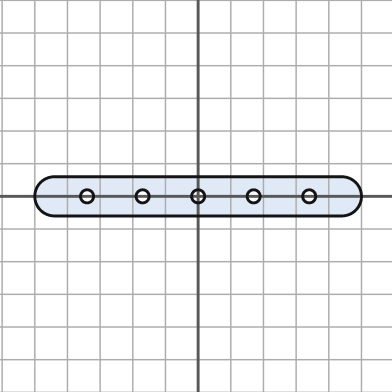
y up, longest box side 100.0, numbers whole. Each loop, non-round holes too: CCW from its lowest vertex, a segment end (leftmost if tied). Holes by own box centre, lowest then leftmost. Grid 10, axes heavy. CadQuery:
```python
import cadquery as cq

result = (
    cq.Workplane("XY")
    .moveTo(-44.0, -6.0)
    .lineTo(44.0, -6.0)
    .threePointArc((50.0, 0.0), (44.0, 6.0))
    .lineTo(-44.0, 6.0)
    .threePointArc((-50.0, 0.0), (-44.0, -6.0))
    .close()
    .moveTo(-34.0, 0.0)
    .circle(2.0)
    .moveTo(-17.0, 0.0)
    .circle(2.0)
    .moveTo(0.0, 0.0)
    .circle(2.0)
    .moveTo(17.0, 0.0)
    .circle(2.0)
    .moveTo(34.0, 0.0)
    .circle(2.0)
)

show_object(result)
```